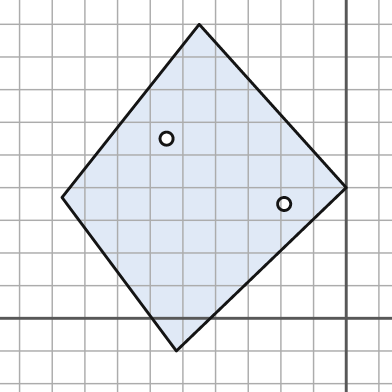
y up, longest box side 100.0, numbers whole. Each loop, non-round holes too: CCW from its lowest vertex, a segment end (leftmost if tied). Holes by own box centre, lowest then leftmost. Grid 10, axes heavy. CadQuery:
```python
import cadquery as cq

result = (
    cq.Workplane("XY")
    .moveTo(-52.0, -10.0)
    .lineTo(0.0, 40.0)
    .lineTo(-45.0, 90.0)
    .lineTo(-87.0, 37.0)
    .close()
    .moveTo(-19.0, 35.0)
    .circle(2.0)
    .moveTo(-55.0, 55.0)
    .circle(2.0)
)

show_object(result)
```